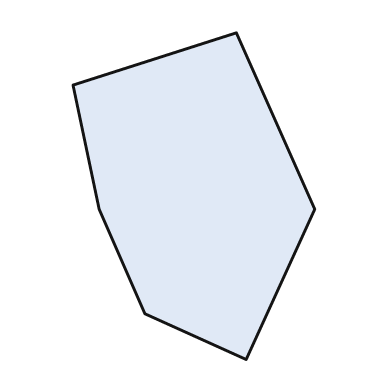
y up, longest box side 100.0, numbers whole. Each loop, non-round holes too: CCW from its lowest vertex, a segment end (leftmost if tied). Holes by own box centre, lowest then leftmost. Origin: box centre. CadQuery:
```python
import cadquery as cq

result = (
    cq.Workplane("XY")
    .moveTo(16.0, -50.0)
    .lineTo(37.0, -4.0)
    .lineTo(13.0, 50.0)
    .lineTo(-37.0, 34.0)
    .lineTo(-29.0, -4.0)
    .lineTo(-15.0, -36.0)
    .close()
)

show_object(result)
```